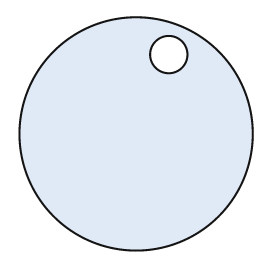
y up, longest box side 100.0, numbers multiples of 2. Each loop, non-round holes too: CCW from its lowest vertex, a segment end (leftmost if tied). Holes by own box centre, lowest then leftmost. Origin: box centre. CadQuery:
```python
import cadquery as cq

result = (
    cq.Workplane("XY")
    .moveTo(0.0, 0.0)
    .circle(50.0)
    .moveTo(14.0, 34.0)
    .circle(8.0)
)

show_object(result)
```